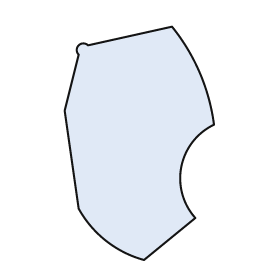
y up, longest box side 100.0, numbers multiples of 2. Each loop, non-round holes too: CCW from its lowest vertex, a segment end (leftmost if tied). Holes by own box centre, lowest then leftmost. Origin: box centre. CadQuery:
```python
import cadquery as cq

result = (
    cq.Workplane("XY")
    .moveTo(2.0, -50.0)
    .lineTo(24.0, -32.0)
    .threePointArc((18.0, -10.0), (32.0, 8.0))
    .threePointArc((26.0, 30.0), (14.0, 50.0))
    .lineTo(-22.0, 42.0)
    .threePointArc((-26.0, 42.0), (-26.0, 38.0))
    .lineTo(-32.0, 14.0)
    .lineTo(-26.0, -28.0)
    .threePointArc((-14.0, -42.0), (2.0, -50.0))
    .close()
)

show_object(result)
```